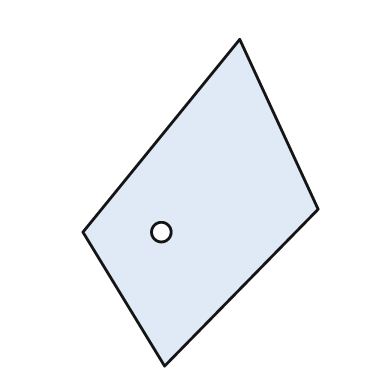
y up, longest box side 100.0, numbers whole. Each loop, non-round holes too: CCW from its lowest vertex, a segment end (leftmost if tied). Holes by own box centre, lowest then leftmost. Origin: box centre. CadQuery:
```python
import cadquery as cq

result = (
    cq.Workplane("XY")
    .moveTo(-11.0, -50.0)
    .lineTo(36.0, -2.0)
    .lineTo(12.0, 50.0)
    .lineTo(-36.0, -9.0)
    .close()
    .moveTo(-12.0, -9.0)
    .circle(3.0)
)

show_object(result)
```